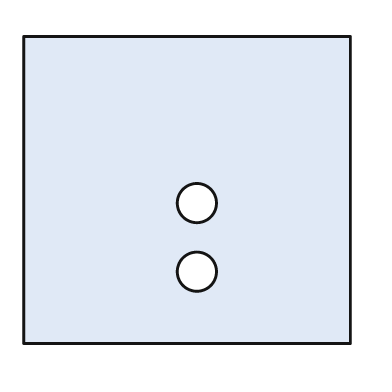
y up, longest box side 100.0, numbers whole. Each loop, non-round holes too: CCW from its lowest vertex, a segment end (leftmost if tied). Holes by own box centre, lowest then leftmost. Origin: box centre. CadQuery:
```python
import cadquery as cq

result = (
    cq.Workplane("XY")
    .moveTo(-50.0, -47.0)
    .lineTo(50.0, -47.0)
    .lineTo(50.0, 47.0)
    .lineTo(-50.0, 47.0)
    .close()
    .moveTo(3.0, -25.0)
    .circle(6.0)
    .moveTo(3.0, -4.0)
    .circle(6.0)
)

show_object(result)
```